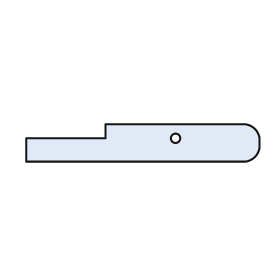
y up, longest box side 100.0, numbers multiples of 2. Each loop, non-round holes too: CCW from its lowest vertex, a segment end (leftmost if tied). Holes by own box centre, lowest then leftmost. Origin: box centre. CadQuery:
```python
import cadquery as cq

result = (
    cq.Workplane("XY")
    .moveTo(-50.0, -8.0)
    .lineTo(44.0, -8.0)
    .threePointArc((48.0, -6.0), (50.0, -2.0))
    .lineTo(50.0, 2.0)
    .threePointArc((48.0, 6.0), (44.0, 8.0))
    .lineTo(-16.0, 8.0)
    .lineTo(-16.0, 2.0)
    .lineTo(-50.0, 2.0)
    .close()
    .moveTo(14.0, 2.0)
    .circle(2.0)
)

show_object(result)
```